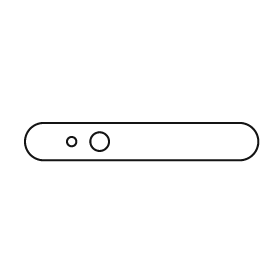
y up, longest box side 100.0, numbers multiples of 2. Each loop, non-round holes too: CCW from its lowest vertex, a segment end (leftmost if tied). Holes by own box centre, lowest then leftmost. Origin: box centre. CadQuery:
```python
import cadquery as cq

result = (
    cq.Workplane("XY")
    .moveTo(-42.0, -8.0)
    .lineTo(42.0, -8.0)
    .threePointArc((50.0, 0.0), (42.0, 8.0))
    .lineTo(-42.0, 8.0)
    .threePointArc((-50.0, 0.0), (-42.0, -8.0))
    .close()
    .moveTo(-30.0, 0.0)
    .circle(2.0)
    .moveTo(-18.0, 0.0)
    .circle(4.0)
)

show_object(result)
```